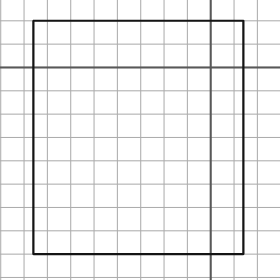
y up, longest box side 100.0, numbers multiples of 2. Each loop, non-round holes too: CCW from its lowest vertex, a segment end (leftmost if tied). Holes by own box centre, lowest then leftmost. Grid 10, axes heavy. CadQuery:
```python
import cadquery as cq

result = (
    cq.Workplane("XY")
    .moveTo(-76.0, -80.0)
    .lineTo(14.0, -80.0)
    .lineTo(14.0, 20.0)
    .lineTo(-76.0, 20.0)
    .close()
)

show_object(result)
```